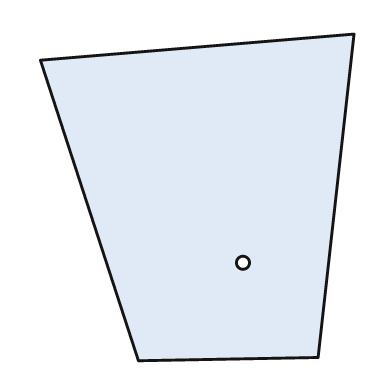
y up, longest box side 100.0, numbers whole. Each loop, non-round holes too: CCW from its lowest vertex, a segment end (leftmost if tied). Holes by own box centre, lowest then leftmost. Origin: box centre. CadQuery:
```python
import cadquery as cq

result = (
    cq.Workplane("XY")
    .moveTo(-18.0, -50.0)
    .lineTo(37.0, -49.0)
    .lineTo(48.0, 50.0)
    .lineTo(-48.0, 42.0)
    .close()
    .moveTo(14.0, -20.0)
    .circle(2.0)
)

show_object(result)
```